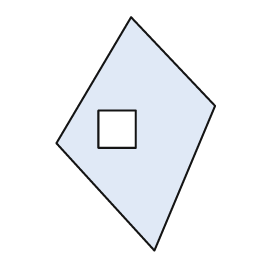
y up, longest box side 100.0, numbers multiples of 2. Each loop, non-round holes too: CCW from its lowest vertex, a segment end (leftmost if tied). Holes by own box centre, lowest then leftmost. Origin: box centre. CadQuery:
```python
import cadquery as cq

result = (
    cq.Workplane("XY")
    .moveTo(8.0, -50.0)
    .lineTo(34.0, 12.0)
    .lineTo(-2.0, 50.0)
    .lineTo(-34.0, -4.0)
    .close()
    .moveTo(-16.0, -6.0)
    .lineTo(0.0, -6.0)
    .lineTo(0.0, 10.0)
    .lineTo(-16.0, 10.0)
    .close()
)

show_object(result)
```